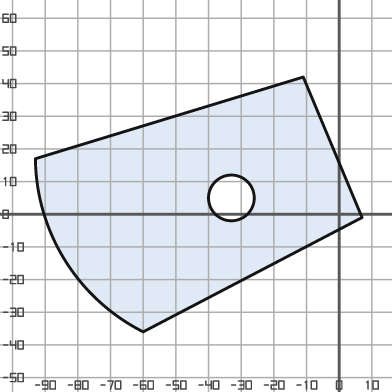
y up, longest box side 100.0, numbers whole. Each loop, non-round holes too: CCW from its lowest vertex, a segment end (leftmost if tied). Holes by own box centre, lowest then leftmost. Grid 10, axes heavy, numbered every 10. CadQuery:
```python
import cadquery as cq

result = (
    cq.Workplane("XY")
    .moveTo(-60.0, -36.0)
    .lineTo(7.0, -1.0)
    .lineTo(-11.0, 42.0)
    .lineTo(-93.0, 17.0)
    .threePointArc((-84.0, -14.0), (-60.0, -36.0))
    .close()
    .moveTo(-33.0, 5.0)
    .circle(7.0)
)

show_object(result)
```